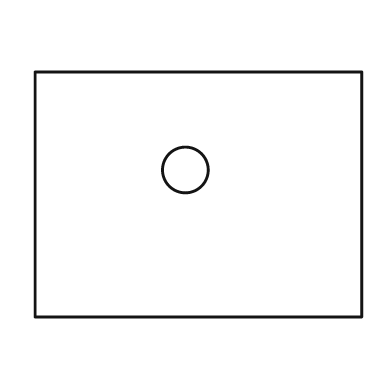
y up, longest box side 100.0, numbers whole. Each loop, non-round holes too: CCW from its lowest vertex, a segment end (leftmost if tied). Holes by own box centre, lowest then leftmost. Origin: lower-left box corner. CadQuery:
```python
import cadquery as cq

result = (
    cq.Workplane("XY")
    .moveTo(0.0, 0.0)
    .lineTo(100.0, 0.0)
    .lineTo(100.0, 75.0)
    .lineTo(0.0, 75.0)
    .close()
    .moveTo(46.0, 45.0)
    .circle(7.0)
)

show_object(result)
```